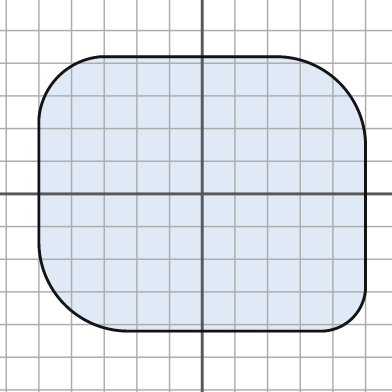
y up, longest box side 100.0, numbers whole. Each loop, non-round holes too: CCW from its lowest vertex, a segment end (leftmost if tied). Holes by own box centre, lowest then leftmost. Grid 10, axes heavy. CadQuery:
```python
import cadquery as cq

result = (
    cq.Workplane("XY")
    .moveTo(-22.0, -42.0)
    .lineTo(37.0, -42.0)
    .threePointArc((46.0, -38.0), (50.0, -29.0))
    .lineTo(50.0, 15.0)
    .threePointArc((42.0, 34.0), (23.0, 42.0))
    .lineTo(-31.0, 42.0)
    .threePointArc((-44.0, 36.0), (-50.0, 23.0))
    .lineTo(-50.0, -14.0)
    .threePointArc((-42.0, -34.0), (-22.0, -42.0))
    .close()
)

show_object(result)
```